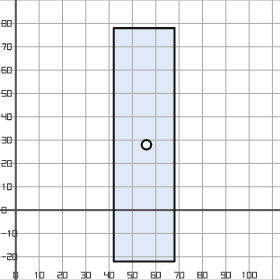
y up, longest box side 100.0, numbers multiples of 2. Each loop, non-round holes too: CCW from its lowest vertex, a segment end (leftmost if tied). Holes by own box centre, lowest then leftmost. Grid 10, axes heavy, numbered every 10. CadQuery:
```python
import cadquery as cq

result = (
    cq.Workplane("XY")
    .moveTo(42.0, -22.0)
    .lineTo(68.0, -22.0)
    .lineTo(68.0, 78.0)
    .lineTo(42.0, 78.0)
    .close()
    .moveTo(56.0, 28.0)
    .circle(2.0)
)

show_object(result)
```